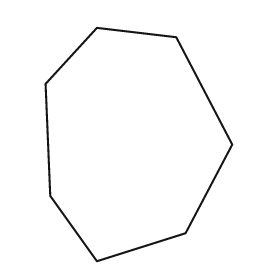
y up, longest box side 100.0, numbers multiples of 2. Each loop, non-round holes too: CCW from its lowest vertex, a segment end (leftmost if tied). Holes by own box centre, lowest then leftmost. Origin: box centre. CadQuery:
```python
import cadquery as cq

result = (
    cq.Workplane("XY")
    .moveTo(-18.0, -50.0)
    .lineTo(20.0, -38.0)
    .lineTo(40.0, 0.0)
    .lineTo(16.0, 46.0)
    .lineTo(-18.0, 50.0)
    .lineTo(-40.0, 26.0)
    .lineTo(-38.0, -22.0)
    .close()
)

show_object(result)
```